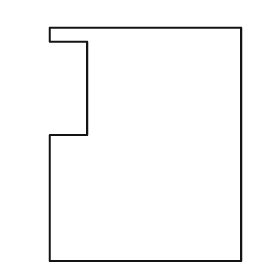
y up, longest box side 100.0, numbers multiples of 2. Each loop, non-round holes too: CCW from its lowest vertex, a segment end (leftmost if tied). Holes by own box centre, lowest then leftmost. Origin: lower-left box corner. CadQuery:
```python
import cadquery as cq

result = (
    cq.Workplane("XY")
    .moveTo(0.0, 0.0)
    .lineTo(82.0, 0.0)
    .lineTo(82.0, 100.0)
    .lineTo(0.0, 100.0)
    .lineTo(0.0, 94.0)
    .lineTo(16.0, 94.0)
    .lineTo(16.0, 54.0)
    .lineTo(0.0, 54.0)
    .close()
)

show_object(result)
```